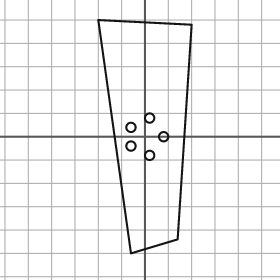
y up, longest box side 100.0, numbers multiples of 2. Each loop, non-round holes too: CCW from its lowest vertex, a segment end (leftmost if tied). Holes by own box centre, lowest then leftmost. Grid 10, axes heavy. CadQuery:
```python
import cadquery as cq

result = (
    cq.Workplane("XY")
    .moveTo(-6.0, -50.0)
    .lineTo(14.0, -44.0)
    .lineTo(20.0, 48.0)
    .lineTo(-20.0, 50.0)
    .close()
    .moveTo(2.0, -8.0)
    .circle(2.0)
    .moveTo(-6.0, -4.0)
    .circle(2.0)
    .moveTo(8.0, 0.0)
    .circle(2.0)
    .moveTo(-6.0, 4.0)
    .circle(2.0)
    .moveTo(2.0, 8.0)
    .circle(2.0)
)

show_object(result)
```